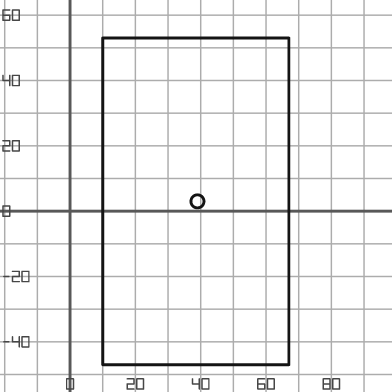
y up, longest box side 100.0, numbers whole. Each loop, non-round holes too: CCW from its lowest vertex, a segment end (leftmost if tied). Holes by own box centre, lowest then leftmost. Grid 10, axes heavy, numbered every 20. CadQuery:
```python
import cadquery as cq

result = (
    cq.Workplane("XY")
    .moveTo(10.0, -47.0)
    .lineTo(67.0, -47.0)
    .lineTo(67.0, 53.0)
    .lineTo(10.0, 53.0)
    .close()
    .moveTo(39.0, 3.0)
    .circle(2.0)
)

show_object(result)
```